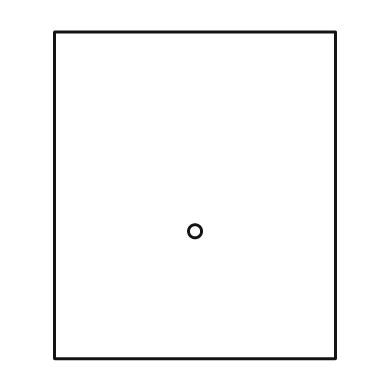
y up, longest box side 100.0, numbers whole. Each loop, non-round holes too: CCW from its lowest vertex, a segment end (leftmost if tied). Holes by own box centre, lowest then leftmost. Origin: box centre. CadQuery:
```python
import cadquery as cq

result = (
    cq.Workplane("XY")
    .moveTo(-43.0, -50.0)
    .lineTo(43.0, -50.0)
    .lineTo(43.0, 50.0)
    .lineTo(-43.0, 50.0)
    .close()
    .moveTo(0.0, -11.0)
    .circle(2.0)
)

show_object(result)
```